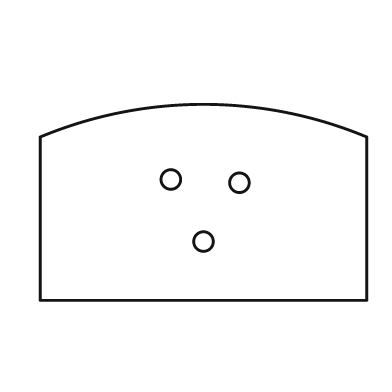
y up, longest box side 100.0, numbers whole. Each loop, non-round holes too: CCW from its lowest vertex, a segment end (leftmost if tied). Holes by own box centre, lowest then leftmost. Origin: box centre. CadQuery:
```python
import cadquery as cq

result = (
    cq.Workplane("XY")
    .moveTo(-50.0, -30.0)
    .lineTo(50.0, -30.0)
    .lineTo(50.0, 20.0)
    .threePointArc((0.0, 30.0), (-50.0, 20.0))
    .close()
    .moveTo(0.0, -12.0)
    .circle(3.0)
    .moveTo(11.0, 6.0)
    .circle(3.0)
    .moveTo(-10.0, 7.0)
    .circle(3.0)
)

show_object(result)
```